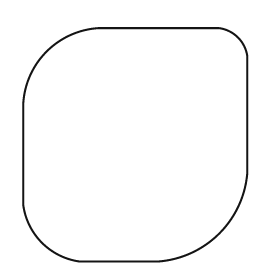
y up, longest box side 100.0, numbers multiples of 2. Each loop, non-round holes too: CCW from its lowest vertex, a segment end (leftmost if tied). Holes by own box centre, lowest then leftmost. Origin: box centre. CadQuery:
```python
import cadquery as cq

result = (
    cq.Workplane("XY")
    .moveTo(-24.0, -50.0)
    .lineTo(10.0, -50.0)
    .threePointArc((36.0, -38.0), (48.0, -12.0))
    .lineTo(48.0, 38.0)
    .threePointArc((44.0, 46.0), (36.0, 50.0))
    .lineTo(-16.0, 50.0)
    .threePointArc((-38.0, 40.0), (-48.0, 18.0))
    .lineTo(-48.0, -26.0)
    .threePointArc((-40.0, -42.0), (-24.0, -50.0))
    .close()
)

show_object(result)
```